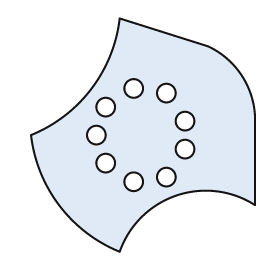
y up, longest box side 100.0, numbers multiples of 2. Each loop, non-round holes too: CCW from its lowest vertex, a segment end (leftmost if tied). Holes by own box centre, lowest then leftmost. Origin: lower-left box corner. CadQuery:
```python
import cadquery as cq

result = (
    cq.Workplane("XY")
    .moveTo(38.0, 0.0)
    .threePointArc((62.0, 24.0), (96.0, 20.0))
    .lineTo(96.0, 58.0)
    .threePointArc((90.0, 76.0), (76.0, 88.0))
    .lineTo(38.0, 100.0)
    .threePointArc((26.0, 70.0), (0.0, 50.0))
    .threePointArc((12.0, 20.0), (38.0, 0.0))
    .close()
    .moveTo(44.0, 30.0)
    .circle(4.0)
    .moveTo(58.0, 32.0)
    .circle(4.0)
    .moveTo(32.0, 38.0)
    .circle(4.0)
    .moveTo(66.0, 44.0)
    .circle(4.0)
    .moveTo(28.0, 50.0)
    .circle(4.0)
    .moveTo(66.0, 56.0)
    .circle(4.0)
    .moveTo(32.0, 62.0)
    .circle(4.0)
    .moveTo(58.0, 68.0)
    .circle(4.0)
    .moveTo(44.0, 70.0)
    .circle(4.0)
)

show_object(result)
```